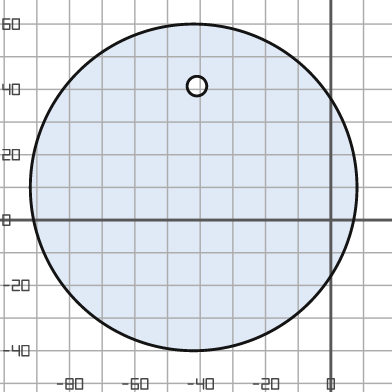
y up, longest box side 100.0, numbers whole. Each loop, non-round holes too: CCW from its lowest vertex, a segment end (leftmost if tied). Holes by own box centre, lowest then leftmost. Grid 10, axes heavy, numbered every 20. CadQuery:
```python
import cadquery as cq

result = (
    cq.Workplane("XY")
    .moveTo(-42.0, 10.0)
    .circle(50.0)
    .moveTo(-41.0, 41.0)
    .circle(3.0)
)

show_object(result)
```